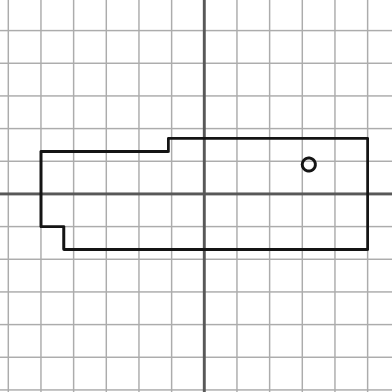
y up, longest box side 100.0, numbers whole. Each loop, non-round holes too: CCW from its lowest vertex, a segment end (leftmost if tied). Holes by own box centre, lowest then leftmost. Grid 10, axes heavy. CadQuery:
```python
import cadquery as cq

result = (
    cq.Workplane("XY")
    .moveTo(-43.0, -17.0)
    .lineTo(50.0, -17.0)
    .lineTo(50.0, 17.0)
    .lineTo(-11.0, 17.0)
    .lineTo(-11.0, 13.0)
    .lineTo(-50.0, 13.0)
    .lineTo(-50.0, -10.0)
    .lineTo(-43.0, -10.0)
    .close()
    .moveTo(32.0, 9.0)
    .circle(2.0)
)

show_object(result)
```